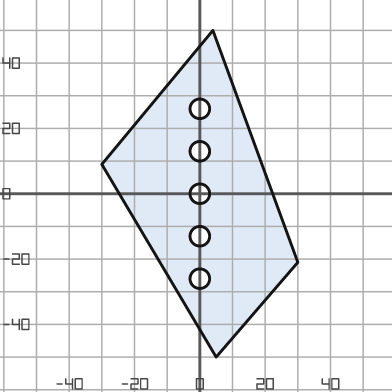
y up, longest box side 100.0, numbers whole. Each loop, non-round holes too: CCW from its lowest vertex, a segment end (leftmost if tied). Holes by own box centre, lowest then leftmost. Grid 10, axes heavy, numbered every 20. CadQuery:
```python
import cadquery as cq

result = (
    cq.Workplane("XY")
    .moveTo(5.0, -50.0)
    .lineTo(30.0, -21.0)
    .lineTo(4.0, 50.0)
    .lineTo(-30.0, 9.0)
    .close()
    .moveTo(0.0, -26.0)
    .circle(3.0)
    .moveTo(0.0, -13.0)
    .circle(3.0)
    .moveTo(0.0, 0.0)
    .circle(3.0)
    .moveTo(0.0, 13.0)
    .circle(3.0)
    .moveTo(0.0, 26.0)
    .circle(3.0)
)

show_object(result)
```